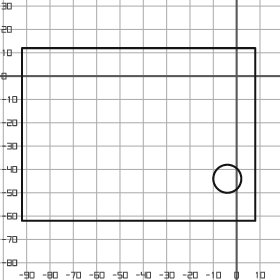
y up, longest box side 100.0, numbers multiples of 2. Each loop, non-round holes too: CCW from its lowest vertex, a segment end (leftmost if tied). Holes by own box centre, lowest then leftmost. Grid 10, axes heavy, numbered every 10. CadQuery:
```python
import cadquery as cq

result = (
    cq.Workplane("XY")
    .moveTo(-92.0, -62.0)
    .lineTo(8.0, -62.0)
    .lineTo(8.0, 12.0)
    .lineTo(-92.0, 12.0)
    .close()
    .moveTo(-4.0, -44.0)
    .circle(6.0)
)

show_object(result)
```